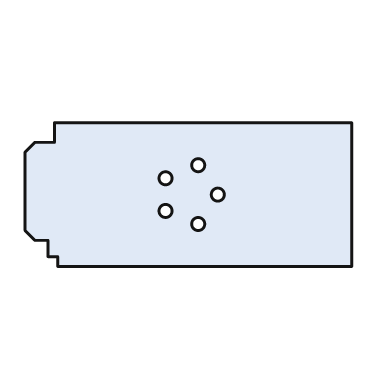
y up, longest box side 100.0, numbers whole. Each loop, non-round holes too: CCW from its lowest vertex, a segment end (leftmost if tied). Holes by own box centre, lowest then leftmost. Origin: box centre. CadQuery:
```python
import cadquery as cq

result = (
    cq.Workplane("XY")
    .moveTo(-40.0, -22.0)
    .lineTo(50.0, -22.0)
    .lineTo(50.0, 22.0)
    .lineTo(-41.0, 22.0)
    .lineTo(-41.0, 16.0)
    .lineTo(-47.0, 16.0)
    .lineTo(-50.0, 13.0)
    .lineTo(-50.0, -11.0)
    .lineTo(-47.0, -14.0)
    .lineTo(-43.0, -14.0)
    .lineTo(-43.0, -19.0)
    .lineTo(-40.0, -19.0)
    .close()
    .moveTo(3.0, -9.0)
    .circle(2.0)
    .moveTo(-7.0, -5.0)
    .circle(2.0)
    .moveTo(9.0, 0.0)
    .circle(2.0)
    .moveTo(-7.0, 5.0)
    .circle(2.0)
    .moveTo(3.0, 9.0)
    .circle(2.0)
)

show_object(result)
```